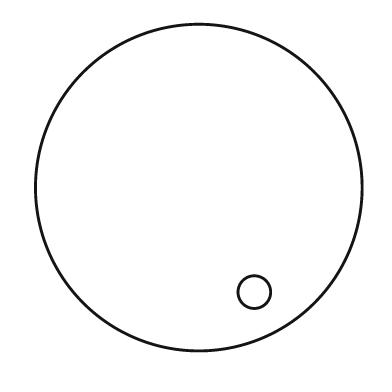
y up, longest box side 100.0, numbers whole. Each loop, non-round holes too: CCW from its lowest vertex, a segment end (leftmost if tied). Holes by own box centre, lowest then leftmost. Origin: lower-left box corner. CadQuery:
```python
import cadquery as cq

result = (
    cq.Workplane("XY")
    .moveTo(50.0, 50.0)
    .circle(50.0)
    .moveTo(67.0, 18.0)
    .circle(5.0)
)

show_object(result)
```